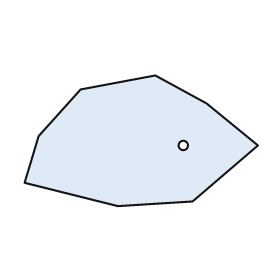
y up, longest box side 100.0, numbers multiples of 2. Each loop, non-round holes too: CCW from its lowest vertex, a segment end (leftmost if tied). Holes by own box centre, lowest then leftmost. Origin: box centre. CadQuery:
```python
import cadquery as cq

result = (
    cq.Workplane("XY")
    .moveTo(-10.0, -28.0)
    .lineTo(22.0, -26.0)
    .lineTo(50.0, -2.0)
    .lineTo(28.0, 16.0)
    .lineTo(6.0, 28.0)
    .lineTo(-26.0, 22.0)
    .lineTo(-44.0, 2.0)
    .lineTo(-50.0, -18.0)
    .close()
    .moveTo(18.0, -2.0)
    .circle(2.0)
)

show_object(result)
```